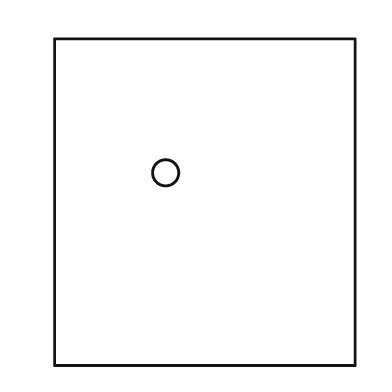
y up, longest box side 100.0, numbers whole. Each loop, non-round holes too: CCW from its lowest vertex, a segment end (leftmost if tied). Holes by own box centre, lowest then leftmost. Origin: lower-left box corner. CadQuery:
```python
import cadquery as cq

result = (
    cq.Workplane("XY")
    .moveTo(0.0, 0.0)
    .lineTo(92.0, 0.0)
    .lineTo(92.0, 100.0)
    .lineTo(0.0, 100.0)
    .close()
    .moveTo(34.0, 59.0)
    .circle(4.0)
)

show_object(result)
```